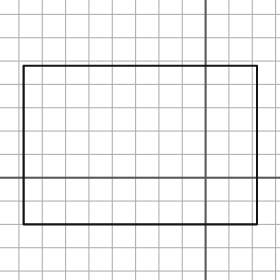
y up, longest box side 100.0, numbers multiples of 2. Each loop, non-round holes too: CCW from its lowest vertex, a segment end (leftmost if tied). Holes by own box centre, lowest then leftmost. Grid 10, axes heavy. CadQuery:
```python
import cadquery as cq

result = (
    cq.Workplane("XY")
    .moveTo(-78.0, -20.0)
    .lineTo(22.0, -20.0)
    .lineTo(22.0, 48.0)
    .lineTo(-78.0, 48.0)
    .close()
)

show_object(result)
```